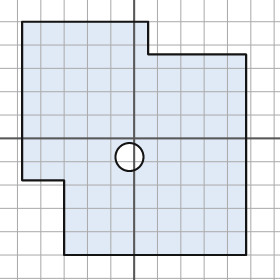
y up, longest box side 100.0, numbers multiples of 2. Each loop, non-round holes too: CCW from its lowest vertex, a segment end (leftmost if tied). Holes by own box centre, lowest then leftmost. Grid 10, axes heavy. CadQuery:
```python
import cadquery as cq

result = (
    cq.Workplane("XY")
    .moveTo(-30.0, -50.0)
    .lineTo(48.0, -50.0)
    .lineTo(48.0, 36.0)
    .lineTo(6.0, 36.0)
    .lineTo(6.0, 50.0)
    .lineTo(-48.0, 50.0)
    .lineTo(-48.0, -18.0)
    .lineTo(-30.0, -18.0)
    .close()
    .moveTo(-2.0, -8.0)
    .circle(6.0)
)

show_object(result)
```